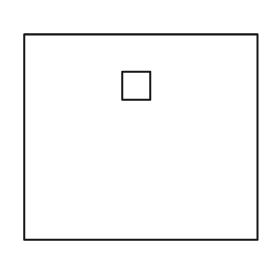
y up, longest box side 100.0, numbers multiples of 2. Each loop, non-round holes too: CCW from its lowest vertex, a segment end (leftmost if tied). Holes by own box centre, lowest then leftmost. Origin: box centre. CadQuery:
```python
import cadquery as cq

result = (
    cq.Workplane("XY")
    .moveTo(-50.0, -44.0)
    .lineTo(50.0, -44.0)
    .lineTo(50.0, 44.0)
    .lineTo(-50.0, 44.0)
    .close()
    .moveTo(-8.0, 16.0)
    .lineTo(4.0, 16.0)
    .lineTo(4.0, 28.0)
    .lineTo(-8.0, 28.0)
    .close()
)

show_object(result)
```